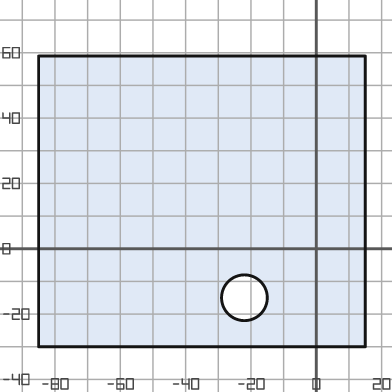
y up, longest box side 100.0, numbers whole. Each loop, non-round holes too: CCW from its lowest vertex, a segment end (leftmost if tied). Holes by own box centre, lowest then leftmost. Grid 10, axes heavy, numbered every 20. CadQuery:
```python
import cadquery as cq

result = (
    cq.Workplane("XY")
    .moveTo(-85.0, -30.0)
    .lineTo(15.0, -30.0)
    .lineTo(15.0, 59.0)
    .lineTo(-85.0, 59.0)
    .close()
    .moveTo(-22.0, -15.0)
    .circle(7.0)
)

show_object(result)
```